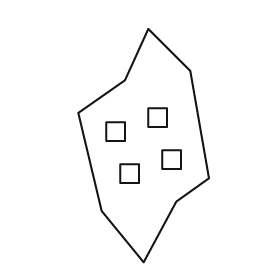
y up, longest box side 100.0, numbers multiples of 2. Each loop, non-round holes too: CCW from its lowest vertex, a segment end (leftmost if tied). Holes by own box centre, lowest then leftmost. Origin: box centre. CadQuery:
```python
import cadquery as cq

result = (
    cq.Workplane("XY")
    .moveTo(0.0, -50.0)
    .lineTo(14.0, -24.0)
    .lineTo(28.0, -14.0)
    .lineTo(20.0, 32.0)
    .lineTo(2.0, 50.0)
    .lineTo(-8.0, 28.0)
    .lineTo(-28.0, 14.0)
    .lineTo(-18.0, -28.0)
    .close()
    .moveTo(-10.0, -16.0)
    .lineTo(-2.0, -16.0)
    .lineTo(-2.0, -8.0)
    .lineTo(-10.0, -8.0)
    .close()
    .moveTo(8.0, -10.0)
    .lineTo(16.0, -10.0)
    .lineTo(16.0, -2.0)
    .lineTo(8.0, -2.0)
    .close()
    .moveTo(-16.0, 2.0)
    .lineTo(-8.0, 2.0)
    .lineTo(-8.0, 10.0)
    .lineTo(-16.0, 10.0)
    .close()
    .moveTo(2.0, 8.0)
    .lineTo(10.0, 8.0)
    .lineTo(10.0, 16.0)
    .lineTo(2.0, 16.0)
    .close()
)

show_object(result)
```